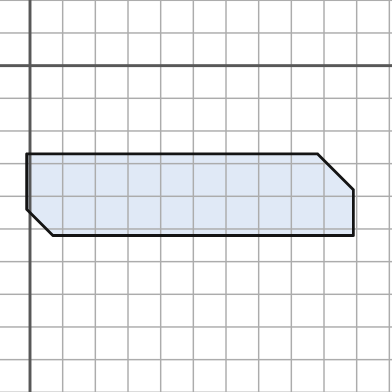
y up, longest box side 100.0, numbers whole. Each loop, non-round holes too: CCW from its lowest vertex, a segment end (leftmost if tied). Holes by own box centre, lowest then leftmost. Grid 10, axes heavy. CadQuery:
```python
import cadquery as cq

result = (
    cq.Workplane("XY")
    .moveTo(7.0, -52.0)
    .lineTo(99.0, -52.0)
    .lineTo(99.0, -38.0)
    .lineTo(88.0, -27.0)
    .lineTo(-1.0, -27.0)
    .lineTo(-1.0, -44.0)
    .close()
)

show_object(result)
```